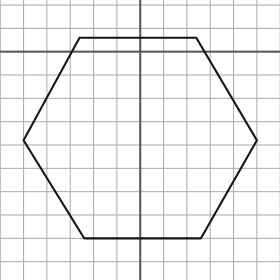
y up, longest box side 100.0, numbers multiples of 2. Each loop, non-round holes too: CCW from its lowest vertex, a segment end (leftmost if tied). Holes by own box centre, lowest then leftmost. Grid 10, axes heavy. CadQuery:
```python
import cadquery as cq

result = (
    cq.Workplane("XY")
    .moveTo(-24.0, -80.0)
    .lineTo(26.0, -80.0)
    .lineTo(50.0, -38.0)
    .lineTo(24.0, 6.0)
    .lineTo(-26.0, 6.0)
    .lineTo(-50.0, -38.0)
    .close()
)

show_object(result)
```